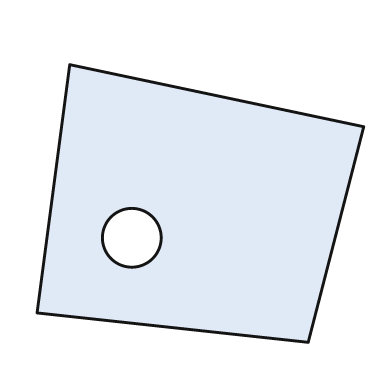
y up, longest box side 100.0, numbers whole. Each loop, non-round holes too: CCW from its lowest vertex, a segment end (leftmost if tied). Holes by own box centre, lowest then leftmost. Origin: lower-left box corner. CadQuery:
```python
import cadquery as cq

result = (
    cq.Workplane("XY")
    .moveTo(83.0, 0.0)
    .lineTo(100.0, 66.0)
    .lineTo(10.0, 85.0)
    .lineTo(0.0, 9.0)
    .close()
    .moveTo(29.0, 32.0)
    .circle(9.0)
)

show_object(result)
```